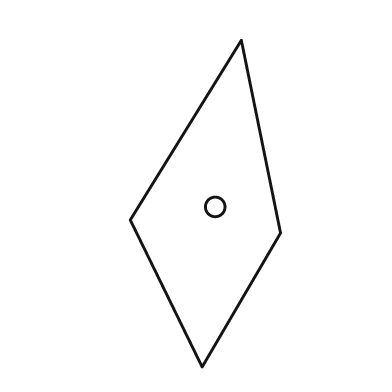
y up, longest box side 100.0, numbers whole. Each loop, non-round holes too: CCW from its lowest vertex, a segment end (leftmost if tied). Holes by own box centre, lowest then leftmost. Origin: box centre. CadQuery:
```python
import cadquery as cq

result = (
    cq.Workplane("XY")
    .moveTo(-1.0, -50.0)
    .lineTo(23.0, -9.0)
    .lineTo(11.0, 50.0)
    .lineTo(-23.0, -5.0)
    .close()
    .moveTo(3.0, -1.0)
    .circle(3.0)
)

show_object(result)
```